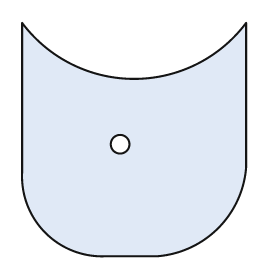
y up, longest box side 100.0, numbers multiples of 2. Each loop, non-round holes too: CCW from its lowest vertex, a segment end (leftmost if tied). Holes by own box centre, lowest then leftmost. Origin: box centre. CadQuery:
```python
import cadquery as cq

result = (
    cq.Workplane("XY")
    .moveTo(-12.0, -50.0)
    .lineTo(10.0, -50.0)
    .threePointArc((36.0, -38.0), (48.0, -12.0))
    .lineTo(48.0, 50.0)
    .threePointArc((0.0, 26.0), (-48.0, 50.0))
    .lineTo(-48.0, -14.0)
    .threePointArc((-38.0, -40.0), (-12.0, -50.0))
    .close()
    .moveTo(-6.0, -2.0)
    .circle(4.0)
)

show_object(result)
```